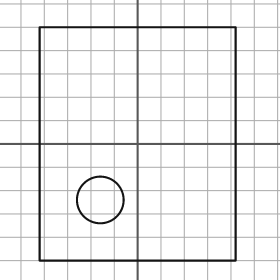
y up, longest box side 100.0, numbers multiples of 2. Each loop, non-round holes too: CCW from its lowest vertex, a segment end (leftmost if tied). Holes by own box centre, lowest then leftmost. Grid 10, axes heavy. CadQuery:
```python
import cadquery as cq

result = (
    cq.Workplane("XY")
    .moveTo(-42.0, -50.0)
    .lineTo(42.0, -50.0)
    .lineTo(42.0, 50.0)
    .lineTo(-42.0, 50.0)
    .close()
    .moveTo(-16.0, -24.0)
    .circle(10.0)
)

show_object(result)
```